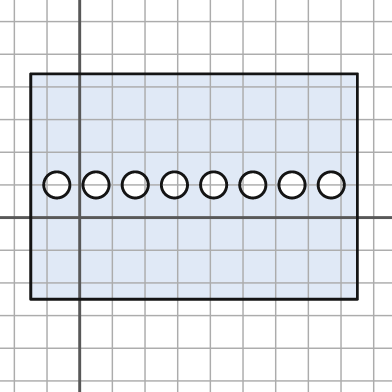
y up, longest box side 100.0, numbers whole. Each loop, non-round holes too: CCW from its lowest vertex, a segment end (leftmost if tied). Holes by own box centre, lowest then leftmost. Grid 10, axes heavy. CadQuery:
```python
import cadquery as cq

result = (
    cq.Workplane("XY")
    .moveTo(-15.0, -25.0)
    .lineTo(85.0, -25.0)
    .lineTo(85.0, 44.0)
    .lineTo(-15.0, 44.0)
    .close()
    .moveTo(-7.0, 10.0)
    .circle(4.0)
    .moveTo(5.0, 10.0)
    .circle(4.0)
    .moveTo(17.0, 10.0)
    .circle(4.0)
    .moveTo(29.0, 10.0)
    .circle(4.0)
    .moveTo(41.0, 10.0)
    .circle(4.0)
    .moveTo(53.0, 10.0)
    .circle(4.0)
    .moveTo(65.0, 10.0)
    .circle(4.0)
    .moveTo(77.0, 10.0)
    .circle(4.0)
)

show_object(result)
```